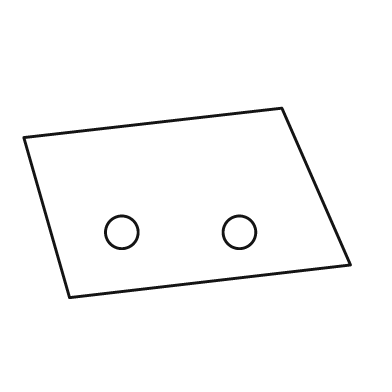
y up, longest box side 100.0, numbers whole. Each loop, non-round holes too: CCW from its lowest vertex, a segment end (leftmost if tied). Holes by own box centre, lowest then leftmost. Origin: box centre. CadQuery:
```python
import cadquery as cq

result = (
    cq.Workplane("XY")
    .moveTo(-36.0, -29.0)
    .lineTo(50.0, -19.0)
    .lineTo(29.0, 29.0)
    .lineTo(-50.0, 20.0)
    .close()
    .moveTo(-20.0, -9.0)
    .circle(5.0)
    .moveTo(16.0, -9.0)
    .circle(5.0)
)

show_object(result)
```